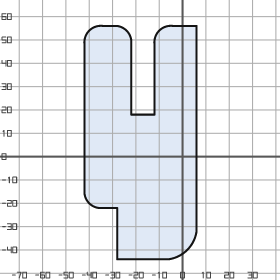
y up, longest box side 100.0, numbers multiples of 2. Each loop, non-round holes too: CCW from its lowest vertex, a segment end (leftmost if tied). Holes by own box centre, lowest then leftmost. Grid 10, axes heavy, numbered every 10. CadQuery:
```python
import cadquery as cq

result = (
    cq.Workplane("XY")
    .moveTo(-28.0, -44.0)
    .lineTo(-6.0, -44.0)
    .threePointArc((2.0, -40.0), (6.0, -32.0))
    .lineTo(6.0, 56.0)
    .lineTo(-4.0, 56.0)
    .threePointArc((-10.0, 54.0), (-12.0, 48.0))
    .lineTo(-12.0, 18.0)
    .lineTo(-22.0, 18.0)
    .lineTo(-22.0, 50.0)
    .threePointArc((-24.0, 54.0), (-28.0, 56.0))
    .lineTo(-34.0, 56.0)
    .threePointArc((-40.0, 54.0), (-42.0, 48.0))
    .lineTo(-42.0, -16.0)
    .threePointArc((-40.0, -20.0), (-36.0, -22.0))
    .lineTo(-28.0, -22.0)
    .close()
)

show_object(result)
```